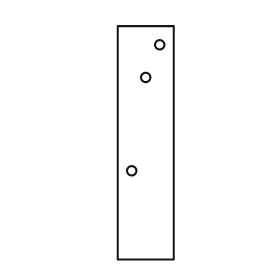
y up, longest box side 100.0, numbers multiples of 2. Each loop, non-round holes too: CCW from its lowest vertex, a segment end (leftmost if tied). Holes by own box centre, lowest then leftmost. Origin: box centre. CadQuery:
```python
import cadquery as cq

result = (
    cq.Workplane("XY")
    .moveTo(-12.0, -50.0)
    .lineTo(12.0, -50.0)
    .lineTo(12.0, 50.0)
    .lineTo(-12.0, 50.0)
    .close()
    .moveTo(-6.0, -12.0)
    .circle(2.0)
    .moveTo(0.0, 28.0)
    .circle(2.0)
    .moveTo(6.0, 42.0)
    .circle(2.0)
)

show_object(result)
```